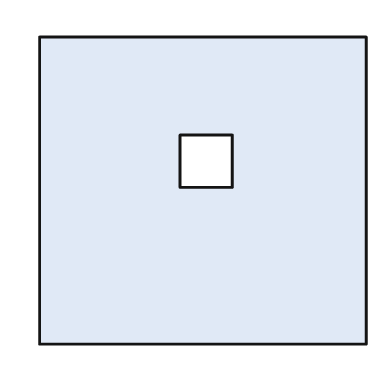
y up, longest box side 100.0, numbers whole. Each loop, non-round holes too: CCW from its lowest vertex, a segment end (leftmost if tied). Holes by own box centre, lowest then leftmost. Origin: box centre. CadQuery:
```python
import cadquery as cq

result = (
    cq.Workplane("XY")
    .moveTo(-50.0, -47.0)
    .lineTo(50.0, -47.0)
    .lineTo(50.0, 47.0)
    .lineTo(-50.0, 47.0)
    .close()
    .moveTo(-7.0, 1.0)
    .lineTo(9.0, 1.0)
    .lineTo(9.0, 17.0)
    .lineTo(-7.0, 17.0)
    .close()
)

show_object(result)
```